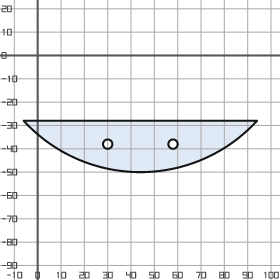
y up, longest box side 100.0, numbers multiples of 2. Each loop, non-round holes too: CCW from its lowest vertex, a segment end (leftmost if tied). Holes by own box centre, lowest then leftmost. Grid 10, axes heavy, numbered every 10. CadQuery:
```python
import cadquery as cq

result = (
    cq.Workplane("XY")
    .moveTo(-6.0, -28.0)
    .threePointArc((44.0, -50.0), (94.0, -28.0))
    .close()
    .moveTo(30.0, -38.0)
    .circle(2.0)
    .moveTo(58.0, -38.0)
    .circle(2.0)
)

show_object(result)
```